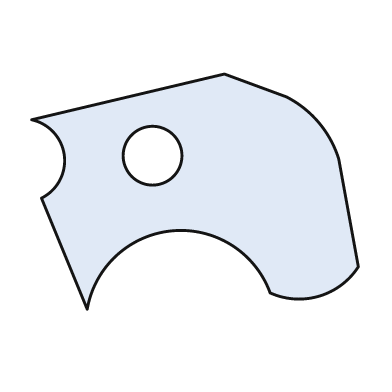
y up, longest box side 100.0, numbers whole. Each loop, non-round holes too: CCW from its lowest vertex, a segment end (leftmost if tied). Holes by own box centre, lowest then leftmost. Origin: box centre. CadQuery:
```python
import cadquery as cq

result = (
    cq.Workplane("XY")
    .moveTo(-33.0, -36.0)
    .threePointArc((-7.0, -12.0), (23.0, -31.0))
    .threePointArc((38.0, -32.0), (50.0, -23.0))
    .lineTo(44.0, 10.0)
    .threePointArc((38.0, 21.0), (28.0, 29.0))
    .lineTo(9.0, 36.0)
    .lineTo(-50.0, 22.0)
    .threePointArc((-40.0, 11.0), (-47.0, -2.0))
    .close()
    .moveTo(-13.0, 11.0)
    .circle(9.0)
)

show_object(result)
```